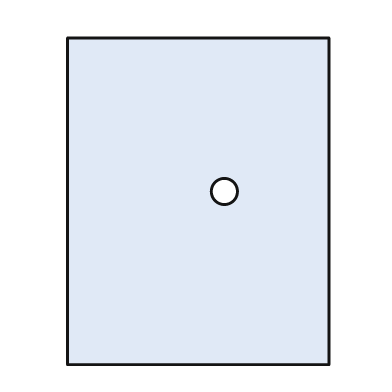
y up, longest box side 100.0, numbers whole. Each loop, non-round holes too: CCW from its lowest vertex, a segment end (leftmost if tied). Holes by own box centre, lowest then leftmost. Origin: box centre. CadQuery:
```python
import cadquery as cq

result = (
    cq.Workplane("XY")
    .moveTo(-40.0, -50.0)
    .lineTo(40.0, -50.0)
    .lineTo(40.0, 50.0)
    .lineTo(-40.0, 50.0)
    .close()
    .moveTo(8.0, 3.0)
    .circle(4.0)
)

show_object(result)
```